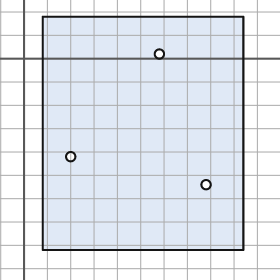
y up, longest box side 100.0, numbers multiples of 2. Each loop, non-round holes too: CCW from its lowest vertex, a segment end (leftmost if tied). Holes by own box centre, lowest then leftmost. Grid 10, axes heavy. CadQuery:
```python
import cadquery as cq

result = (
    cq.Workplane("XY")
    .moveTo(8.0, -82.0)
    .lineTo(94.0, -82.0)
    .lineTo(94.0, 18.0)
    .lineTo(8.0, 18.0)
    .close()
    .moveTo(78.0, -54.0)
    .circle(2.0)
    .moveTo(20.0, -42.0)
    .circle(2.0)
    .moveTo(58.0, 2.0)
    .circle(2.0)
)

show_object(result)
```